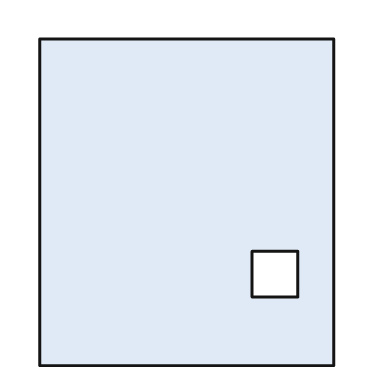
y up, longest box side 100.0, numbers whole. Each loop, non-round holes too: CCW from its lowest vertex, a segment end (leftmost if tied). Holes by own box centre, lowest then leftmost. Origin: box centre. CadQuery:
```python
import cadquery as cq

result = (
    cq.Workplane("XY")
    .moveTo(-45.0, -50.0)
    .lineTo(45.0, -50.0)
    .lineTo(45.0, 50.0)
    .lineTo(-45.0, 50.0)
    .close()
    .moveTo(20.0, -29.0)
    .lineTo(34.0, -29.0)
    .lineTo(34.0, -15.0)
    .lineTo(20.0, -15.0)
    .close()
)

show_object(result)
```